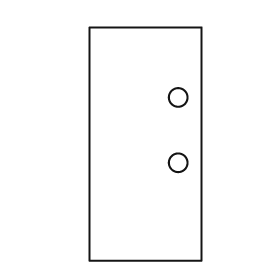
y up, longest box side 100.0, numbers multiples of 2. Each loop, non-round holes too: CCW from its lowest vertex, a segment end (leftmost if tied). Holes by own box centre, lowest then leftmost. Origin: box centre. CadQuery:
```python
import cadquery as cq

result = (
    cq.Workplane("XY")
    .moveTo(-24.0, -50.0)
    .lineTo(24.0, -50.0)
    .lineTo(24.0, 50.0)
    .lineTo(-24.0, 50.0)
    .close()
    .moveTo(14.0, -8.0)
    .circle(4.0)
    .moveTo(14.0, 20.0)
    .circle(4.0)
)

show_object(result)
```